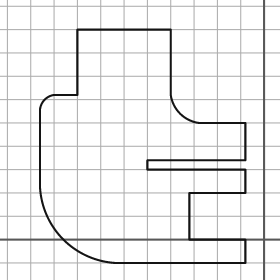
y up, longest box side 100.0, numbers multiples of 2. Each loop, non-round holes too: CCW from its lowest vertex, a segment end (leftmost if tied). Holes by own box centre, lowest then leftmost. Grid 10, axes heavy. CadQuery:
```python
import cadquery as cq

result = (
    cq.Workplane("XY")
    .moveTo(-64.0, -10.0)
    .lineTo(-8.0, -10.0)
    .lineTo(-8.0, 0.0)
    .lineTo(-32.0, 0.0)
    .lineTo(-32.0, 20.0)
    .lineTo(-8.0, 20.0)
    .lineTo(-8.0, 30.0)
    .lineTo(-50.0, 30.0)
    .lineTo(-50.0, 34.0)
    .lineTo(-8.0, 34.0)
    .lineTo(-8.0, 50.0)
    .lineTo(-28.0, 50.0)
    .threePointArc((-36.0, 54.0), (-40.0, 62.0))
    .lineTo(-40.0, 90.0)
    .lineTo(-80.0, 90.0)
    .lineTo(-80.0, 62.0)
    .lineTo(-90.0, 62.0)
    .threePointArc((-94.0, 60.0), (-96.0, 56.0))
    .lineTo(-96.0, 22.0)
    .threePointArc((-86.0, 0.0), (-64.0, -10.0))
    .close()
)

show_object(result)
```